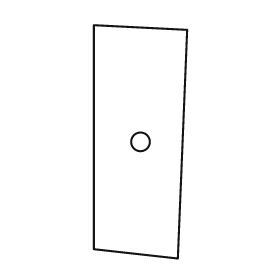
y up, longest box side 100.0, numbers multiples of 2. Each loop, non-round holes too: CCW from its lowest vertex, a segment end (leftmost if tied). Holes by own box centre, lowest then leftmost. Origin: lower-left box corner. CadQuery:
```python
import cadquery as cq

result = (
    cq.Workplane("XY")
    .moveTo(36.0, 0.0)
    .lineTo(40.0, 98.0)
    .lineTo(0.0, 100.0)
    .lineTo(0.0, 4.0)
    .close()
    .moveTo(20.0, 50.0)
    .circle(4.0)
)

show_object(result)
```